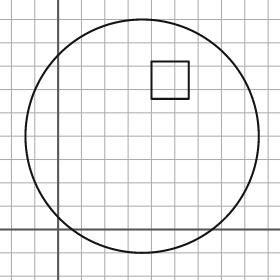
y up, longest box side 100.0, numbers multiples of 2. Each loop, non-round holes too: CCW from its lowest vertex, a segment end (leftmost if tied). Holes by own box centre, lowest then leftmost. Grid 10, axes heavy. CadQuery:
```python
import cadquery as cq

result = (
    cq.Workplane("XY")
    .moveTo(36.0, 40.0)
    .circle(50.0)
    .moveTo(40.0, 56.0)
    .lineTo(56.0, 56.0)
    .lineTo(56.0, 72.0)
    .lineTo(40.0, 72.0)
    .close()
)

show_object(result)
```